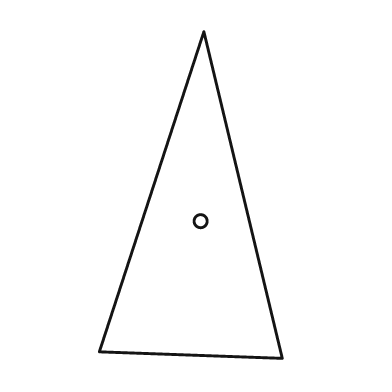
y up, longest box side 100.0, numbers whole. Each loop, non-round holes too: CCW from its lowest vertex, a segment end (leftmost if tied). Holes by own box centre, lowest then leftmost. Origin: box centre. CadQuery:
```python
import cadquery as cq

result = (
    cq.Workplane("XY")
    .moveTo(28.0, -50.0)
    .lineTo(4.0, 50.0)
    .lineTo(-28.0, -48.0)
    .close()
    .moveTo(3.0, -8.0)
    .circle(2.0)
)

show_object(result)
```